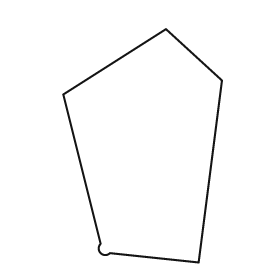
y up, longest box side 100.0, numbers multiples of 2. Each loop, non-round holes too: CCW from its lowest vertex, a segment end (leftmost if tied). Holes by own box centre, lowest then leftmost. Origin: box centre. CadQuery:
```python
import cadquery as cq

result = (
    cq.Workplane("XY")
    .moveTo(24.0, -50.0)
    .lineTo(34.0, 28.0)
    .lineTo(10.0, 50.0)
    .lineTo(-34.0, 22.0)
    .lineTo(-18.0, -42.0)
    .threePointArc((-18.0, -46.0), (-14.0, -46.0))
    .close()
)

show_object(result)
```